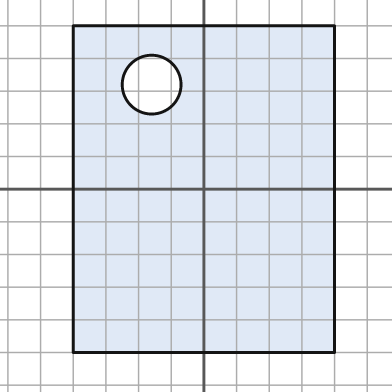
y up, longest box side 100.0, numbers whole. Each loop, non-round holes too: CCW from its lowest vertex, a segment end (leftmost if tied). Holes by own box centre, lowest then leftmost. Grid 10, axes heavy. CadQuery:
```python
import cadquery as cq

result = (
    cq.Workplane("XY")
    .moveTo(-40.0, -50.0)
    .lineTo(40.0, -50.0)
    .lineTo(40.0, 50.0)
    .lineTo(-40.0, 50.0)
    .close()
    .moveTo(-16.0, 32.0)
    .circle(9.0)
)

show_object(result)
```